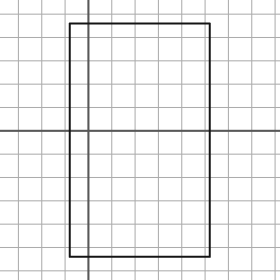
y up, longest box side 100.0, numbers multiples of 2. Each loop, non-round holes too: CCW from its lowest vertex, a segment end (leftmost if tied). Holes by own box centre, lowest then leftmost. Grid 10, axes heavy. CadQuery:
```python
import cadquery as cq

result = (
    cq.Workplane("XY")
    .moveTo(-8.0, -54.0)
    .lineTo(52.0, -54.0)
    .lineTo(52.0, 46.0)
    .lineTo(-8.0, 46.0)
    .close()
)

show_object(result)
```